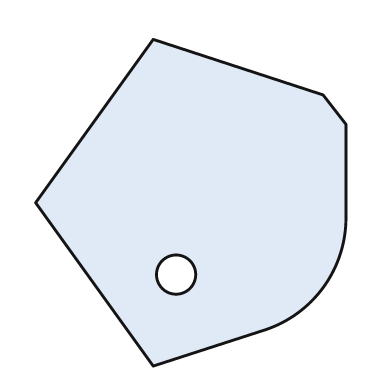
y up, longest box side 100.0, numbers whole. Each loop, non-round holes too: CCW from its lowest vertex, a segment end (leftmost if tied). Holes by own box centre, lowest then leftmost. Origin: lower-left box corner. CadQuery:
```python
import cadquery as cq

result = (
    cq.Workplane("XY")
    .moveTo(36.0, 0.0)
    .lineTo(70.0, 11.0)
    .threePointArc((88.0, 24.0), (95.0, 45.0))
    .lineTo(95.0, 74.0)
    .lineTo(88.0, 83.0)
    .lineTo(36.0, 100.0)
    .lineTo(0.0, 50.0)
    .close()
    .moveTo(43.0, 28.0)
    .circle(6.0)
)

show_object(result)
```